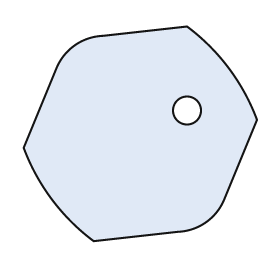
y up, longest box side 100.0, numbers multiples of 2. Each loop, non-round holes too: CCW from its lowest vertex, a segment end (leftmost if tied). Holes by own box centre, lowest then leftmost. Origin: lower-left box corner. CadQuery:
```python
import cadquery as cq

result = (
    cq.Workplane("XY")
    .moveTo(30.0, 0.0)
    .lineTo(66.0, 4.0)
    .threePointArc((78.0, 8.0), (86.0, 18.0))
    .lineTo(100.0, 52.0)
    .threePointArc((88.0, 74.0), (70.0, 92.0))
    .lineTo(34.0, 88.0)
    .threePointArc((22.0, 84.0), (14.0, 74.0))
    .lineTo(0.0, 40.0)
    .threePointArc((12.0, 18.0), (30.0, 0.0))
    .close()
    .moveTo(70.0, 56.0)
    .circle(6.0)
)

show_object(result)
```